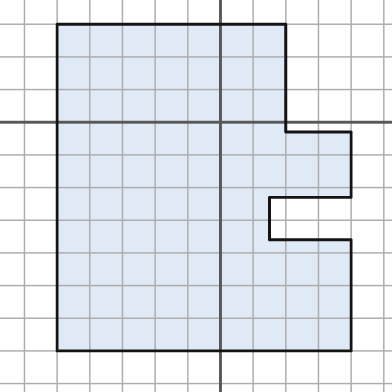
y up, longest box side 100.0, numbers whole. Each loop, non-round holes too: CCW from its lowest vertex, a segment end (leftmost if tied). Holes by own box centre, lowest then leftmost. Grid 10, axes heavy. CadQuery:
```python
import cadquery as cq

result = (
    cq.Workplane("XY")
    .moveTo(-50.0, -70.0)
    .lineTo(40.0, -70.0)
    .lineTo(40.0, -36.0)
    .lineTo(15.0, -36.0)
    .lineTo(15.0, -23.0)
    .lineTo(40.0, -23.0)
    .lineTo(40.0, -3.0)
    .lineTo(20.0, -3.0)
    .lineTo(20.0, 30.0)
    .lineTo(-50.0, 30.0)
    .close()
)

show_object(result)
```